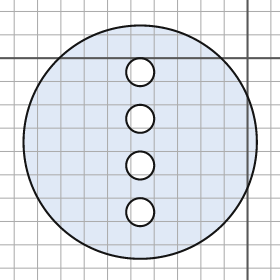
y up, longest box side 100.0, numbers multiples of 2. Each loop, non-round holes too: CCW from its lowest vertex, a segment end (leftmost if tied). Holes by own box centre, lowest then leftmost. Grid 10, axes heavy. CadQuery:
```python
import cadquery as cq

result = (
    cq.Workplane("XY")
    .moveTo(-46.0, -36.0)
    .circle(50.0)
    .moveTo(-46.0, -66.0)
    .circle(6.0)
    .moveTo(-46.0, -46.0)
    .circle(6.0)
    .moveTo(-46.0, -26.0)
    .circle(6.0)
    .moveTo(-46.0, -6.0)
    .circle(6.0)
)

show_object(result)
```